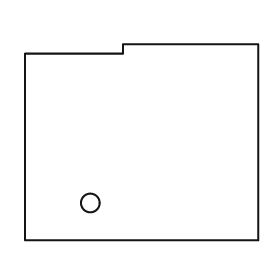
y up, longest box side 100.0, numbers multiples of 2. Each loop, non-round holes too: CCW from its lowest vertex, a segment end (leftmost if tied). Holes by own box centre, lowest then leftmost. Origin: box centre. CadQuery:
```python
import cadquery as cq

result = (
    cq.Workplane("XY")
    .moveTo(-50.0, -42.0)
    .lineTo(50.0, -42.0)
    .lineTo(50.0, 42.0)
    .lineTo(-8.0, 42.0)
    .lineTo(-8.0, 38.0)
    .lineTo(-50.0, 38.0)
    .close()
    .moveTo(-22.0, -26.0)
    .circle(4.0)
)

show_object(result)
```